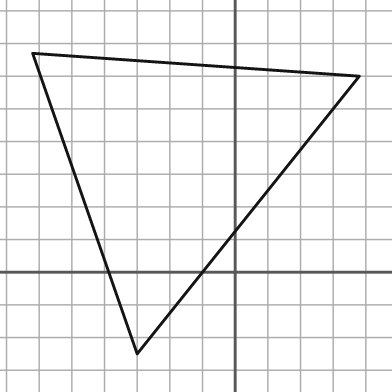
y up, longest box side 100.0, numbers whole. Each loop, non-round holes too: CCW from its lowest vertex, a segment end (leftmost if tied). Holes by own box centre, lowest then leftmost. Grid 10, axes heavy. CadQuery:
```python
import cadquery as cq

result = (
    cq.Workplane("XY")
    .moveTo(-30.0, -25.0)
    .lineTo(38.0, 60.0)
    .lineTo(-62.0, 67.0)
    .close()
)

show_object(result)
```